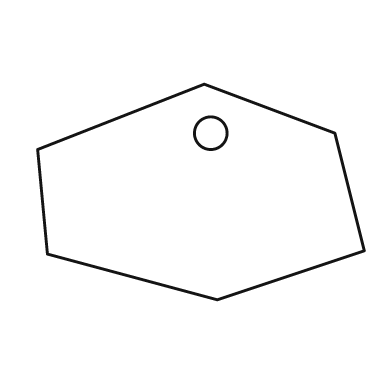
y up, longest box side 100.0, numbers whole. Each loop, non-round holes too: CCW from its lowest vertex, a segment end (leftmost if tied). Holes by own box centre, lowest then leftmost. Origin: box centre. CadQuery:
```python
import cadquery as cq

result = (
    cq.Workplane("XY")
    .moveTo(5.0, -33.0)
    .lineTo(50.0, -18.0)
    .lineTo(41.0, 18.0)
    .lineTo(1.0, 33.0)
    .lineTo(-50.0, 13.0)
    .lineTo(-47.0, -19.0)
    .close()
    .moveTo(3.0, 18.0)
    .circle(5.0)
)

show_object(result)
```